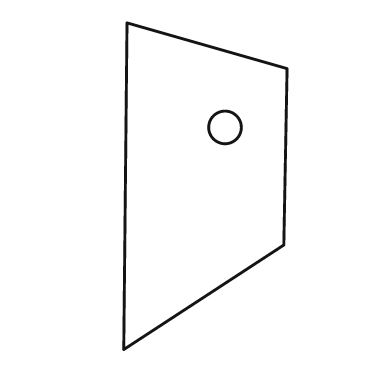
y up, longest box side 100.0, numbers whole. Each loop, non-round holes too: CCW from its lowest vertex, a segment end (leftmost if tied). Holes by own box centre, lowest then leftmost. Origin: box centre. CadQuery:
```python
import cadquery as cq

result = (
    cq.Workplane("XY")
    .moveTo(-25.0, -50.0)
    .lineTo(24.0, -18.0)
    .lineTo(25.0, 36.0)
    .lineTo(-24.0, 50.0)
    .close()
    .moveTo(6.0, 18.0)
    .circle(5.0)
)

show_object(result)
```